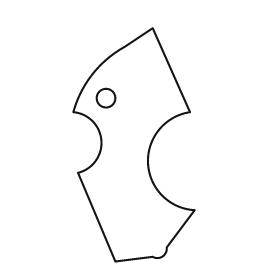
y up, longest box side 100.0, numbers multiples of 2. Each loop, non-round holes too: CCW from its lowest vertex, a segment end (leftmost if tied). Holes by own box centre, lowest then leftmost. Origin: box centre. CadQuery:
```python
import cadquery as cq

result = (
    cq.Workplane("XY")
    .moveTo(-8.0, -50.0)
    .lineTo(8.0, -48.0)
    .threePointArc((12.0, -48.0), (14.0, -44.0))
    .lineTo(26.0, -28.0)
    .threePointArc((6.0, -8.0), (24.0, 14.0))
    .lineTo(8.0, 50.0)
    .lineTo(-4.0, 42.0)
    .threePointArc((-18.0, 30.0), (-26.0, 14.0))
    .threePointArc((-14.0, 2.0), (-24.0, -12.0))
    .close()
    .moveTo(-12.0, 20.0)
    .circle(4.0)
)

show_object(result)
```